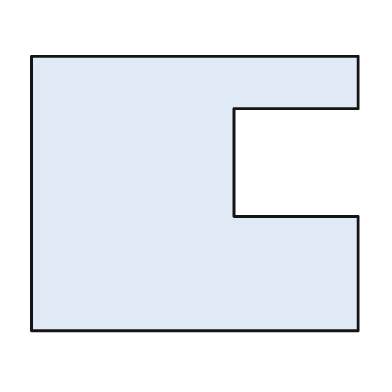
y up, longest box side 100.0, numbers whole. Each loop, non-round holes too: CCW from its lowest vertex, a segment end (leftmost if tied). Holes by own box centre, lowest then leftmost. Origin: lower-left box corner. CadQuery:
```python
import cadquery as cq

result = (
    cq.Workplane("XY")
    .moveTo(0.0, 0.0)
    .lineTo(100.0, 0.0)
    .lineTo(100.0, 35.0)
    .lineTo(62.0, 35.0)
    .lineTo(62.0, 68.0)
    .lineTo(100.0, 68.0)
    .lineTo(100.0, 84.0)
    .lineTo(0.0, 84.0)
    .close()
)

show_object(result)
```